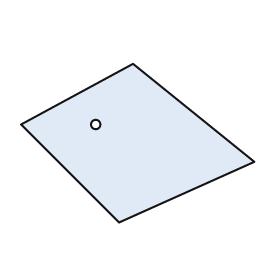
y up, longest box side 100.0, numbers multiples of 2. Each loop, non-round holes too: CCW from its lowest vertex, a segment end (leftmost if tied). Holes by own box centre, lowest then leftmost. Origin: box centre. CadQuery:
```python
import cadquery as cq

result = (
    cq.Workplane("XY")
    .moveTo(-8.0, -34.0)
    .lineTo(50.0, -8.0)
    .lineTo(-2.0, 34.0)
    .lineTo(-50.0, 8.0)
    .close()
    .moveTo(-18.0, 8.0)
    .circle(2.0)
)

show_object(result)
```